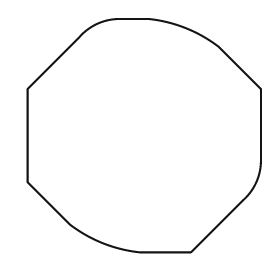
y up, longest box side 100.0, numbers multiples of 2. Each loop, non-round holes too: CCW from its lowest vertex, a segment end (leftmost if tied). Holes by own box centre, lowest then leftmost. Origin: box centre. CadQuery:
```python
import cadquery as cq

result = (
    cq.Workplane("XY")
    .moveTo(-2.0, -50.0)
    .lineTo(20.0, -50.0)
    .lineTo(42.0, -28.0)
    .threePointArc((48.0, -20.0), (50.0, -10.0))
    .lineTo(50.0, 20.0)
    .lineTo(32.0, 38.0)
    .threePointArc((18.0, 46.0), (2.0, 50.0))
    .lineTo(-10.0, 50.0)
    .threePointArc((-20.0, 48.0), (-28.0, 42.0))
    .lineTo(-50.0, 20.0)
    .lineTo(-50.0, -20.0)
    .lineTo(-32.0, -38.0)
    .threePointArc((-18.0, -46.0), (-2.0, -50.0))
    .close()
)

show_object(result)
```